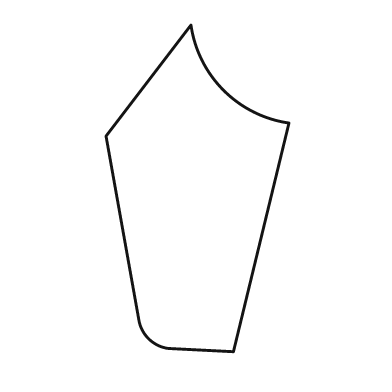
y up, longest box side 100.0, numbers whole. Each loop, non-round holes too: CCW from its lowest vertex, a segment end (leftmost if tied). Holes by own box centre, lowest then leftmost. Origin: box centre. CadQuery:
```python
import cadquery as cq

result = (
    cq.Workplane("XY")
    .moveTo(11.0, -50.0)
    .lineTo(28.0, 20.0)
    .threePointArc((8.0, 30.0), (-2.0, 50.0))
    .lineTo(-28.0, 16.0)
    .lineTo(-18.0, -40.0)
    .threePointArc((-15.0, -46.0), (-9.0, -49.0))
    .close()
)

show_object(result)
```